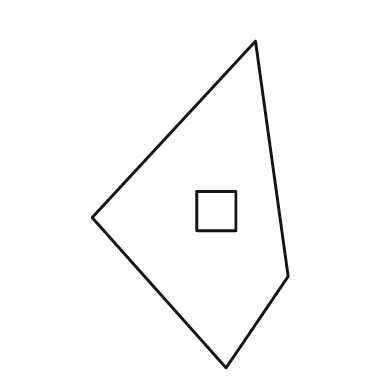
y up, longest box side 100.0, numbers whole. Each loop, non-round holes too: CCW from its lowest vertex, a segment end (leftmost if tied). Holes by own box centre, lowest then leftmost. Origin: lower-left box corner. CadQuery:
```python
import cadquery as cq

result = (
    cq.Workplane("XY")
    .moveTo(41.0, 0.0)
    .lineTo(60.0, 28.0)
    .lineTo(50.0, 100.0)
    .lineTo(0.0, 46.0)
    .close()
    .moveTo(32.0, 42.0)
    .lineTo(44.0, 42.0)
    .lineTo(44.0, 54.0)
    .lineTo(32.0, 54.0)
    .close()
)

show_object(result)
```